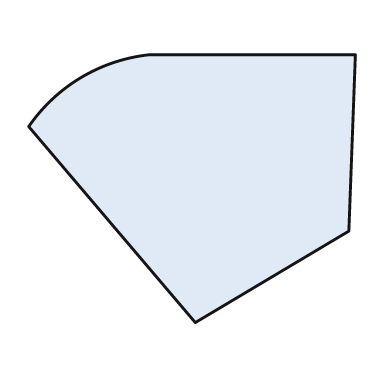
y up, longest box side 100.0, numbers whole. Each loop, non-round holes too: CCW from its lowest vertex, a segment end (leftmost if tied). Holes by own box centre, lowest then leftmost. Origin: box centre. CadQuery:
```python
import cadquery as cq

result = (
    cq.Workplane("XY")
    .moveTo(1.0, -41.0)
    .lineTo(48.0, -13.0)
    .lineTo(50.0, 41.0)
    .lineTo(-13.0, 41.0)
    .threePointArc((-34.0, 34.0), (-50.0, 19.0))
    .close()
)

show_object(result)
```